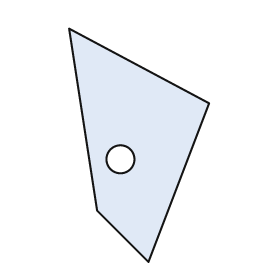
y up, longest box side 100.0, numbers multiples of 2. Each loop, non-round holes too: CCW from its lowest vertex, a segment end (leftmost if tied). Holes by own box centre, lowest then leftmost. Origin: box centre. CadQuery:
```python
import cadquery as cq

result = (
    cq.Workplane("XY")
    .moveTo(4.0, -50.0)
    .lineTo(30.0, 18.0)
    .lineTo(-30.0, 50.0)
    .lineTo(-18.0, -28.0)
    .close()
    .moveTo(-8.0, -6.0)
    .circle(6.0)
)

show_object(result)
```